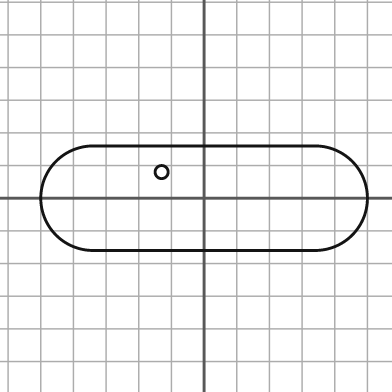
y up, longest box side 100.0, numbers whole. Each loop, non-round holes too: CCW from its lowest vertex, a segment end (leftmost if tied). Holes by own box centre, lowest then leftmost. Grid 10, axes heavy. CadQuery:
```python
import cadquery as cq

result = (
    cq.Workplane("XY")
    .moveTo(-34.0, -16.0)
    .lineTo(34.0, -16.0)
    .threePointArc((50.0, 0.0), (34.0, 16.0))
    .lineTo(-34.0, 16.0)
    .threePointArc((-50.0, 0.0), (-34.0, -16.0))
    .close()
    .moveTo(-13.0, 8.0)
    .circle(2.0)
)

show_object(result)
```